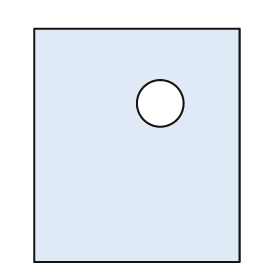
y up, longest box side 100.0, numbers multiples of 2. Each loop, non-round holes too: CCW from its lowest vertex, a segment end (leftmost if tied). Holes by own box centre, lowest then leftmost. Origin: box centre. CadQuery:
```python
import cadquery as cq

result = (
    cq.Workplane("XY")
    .moveTo(-44.0, -50.0)
    .lineTo(44.0, -50.0)
    .lineTo(44.0, 50.0)
    .lineTo(-44.0, 50.0)
    .close()
    .moveTo(10.0, 18.0)
    .circle(10.0)
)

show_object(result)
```